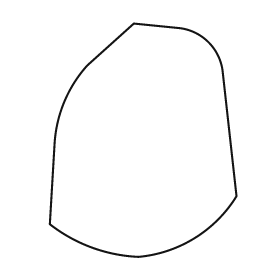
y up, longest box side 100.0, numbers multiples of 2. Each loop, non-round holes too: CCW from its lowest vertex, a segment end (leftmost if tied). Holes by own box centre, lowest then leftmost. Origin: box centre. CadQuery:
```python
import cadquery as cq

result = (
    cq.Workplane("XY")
    .moveTo(-2.0, -50.0)
    .threePointArc((22.0, -42.0), (40.0, -24.0))
    .lineTo(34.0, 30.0)
    .threePointArc((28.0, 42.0), (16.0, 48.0))
    .lineTo(-4.0, 50.0)
    .lineTo(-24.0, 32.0)
    .threePointArc((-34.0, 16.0), (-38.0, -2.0))
    .lineTo(-40.0, -36.0)
    .threePointArc((-22.0, -46.0), (-2.0, -50.0))
    .close()
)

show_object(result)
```